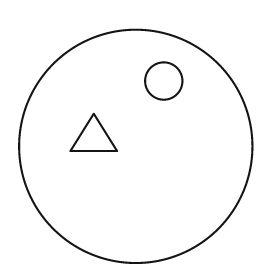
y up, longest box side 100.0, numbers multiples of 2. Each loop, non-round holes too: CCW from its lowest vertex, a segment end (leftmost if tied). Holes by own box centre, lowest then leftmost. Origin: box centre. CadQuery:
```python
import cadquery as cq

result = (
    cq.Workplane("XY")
    .moveTo(0.0, 0.0)
    .circle(50.0)
    .moveTo(-28.0, -2.0)
    .lineTo(-8.0, -2.0)
    .lineTo(-18.0, 14.0)
    .close()
    .moveTo(12.0, 28.0)
    .circle(8.0)
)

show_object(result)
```